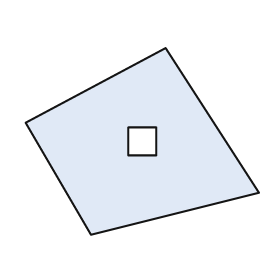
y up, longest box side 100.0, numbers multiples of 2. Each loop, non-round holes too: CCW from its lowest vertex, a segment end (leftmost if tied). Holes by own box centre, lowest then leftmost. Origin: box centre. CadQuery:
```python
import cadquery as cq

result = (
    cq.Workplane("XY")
    .moveTo(-22.0, -40.0)
    .lineTo(50.0, -22.0)
    .lineTo(10.0, 40.0)
    .lineTo(-50.0, 8.0)
    .close()
    .moveTo(-6.0, -6.0)
    .lineTo(6.0, -6.0)
    .lineTo(6.0, 6.0)
    .lineTo(-6.0, 6.0)
    .close()
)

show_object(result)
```